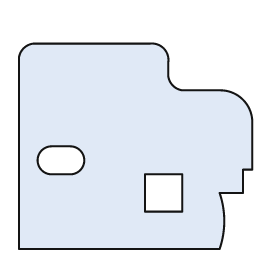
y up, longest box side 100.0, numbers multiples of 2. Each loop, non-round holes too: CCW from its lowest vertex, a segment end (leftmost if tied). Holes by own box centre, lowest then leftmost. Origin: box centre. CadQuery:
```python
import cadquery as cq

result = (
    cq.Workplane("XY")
    .moveTo(-50.0, -44.0)
    .lineTo(36.0, -44.0)
    .threePointArc((38.0, -32.0), (36.0, -20.0))
    .lineTo(46.0, -20.0)
    .lineTo(46.0, -10.0)
    .lineTo(50.0, -10.0)
    .lineTo(50.0, 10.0)
    .threePointArc((46.0, 20.0), (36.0, 24.0))
    .lineTo(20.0, 24.0)
    .threePointArc((16.0, 26.0), (14.0, 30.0))
    .lineTo(14.0, 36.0)
    .threePointArc((12.0, 42.0), (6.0, 44.0))
    .lineTo(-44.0, 44.0)
    .threePointArc((-48.0, 42.0), (-50.0, 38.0))
    .close()
    .moveTo(4.0, -28.0)
    .lineTo(20.0, -28.0)
    .lineTo(20.0, -12.0)
    .lineTo(4.0, -12.0)
    .close()
    .moveTo(-36.0, -12.0)
    .lineTo(-28.0, -12.0)
    .threePointArc((-22.0, -6.0), (-28.0, 0.0))
    .lineTo(-36.0, 0.0)
    .threePointArc((-42.0, -6.0), (-36.0, -12.0))
    .close()
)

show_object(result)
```